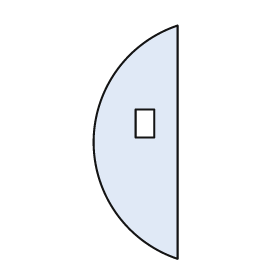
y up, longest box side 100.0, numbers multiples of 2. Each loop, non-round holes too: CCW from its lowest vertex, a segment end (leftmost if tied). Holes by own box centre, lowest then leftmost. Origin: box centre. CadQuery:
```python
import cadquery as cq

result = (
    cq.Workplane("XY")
    .moveTo(18.0, -50.0)
    .lineTo(18.0, 50.0)
    .threePointArc((-18.0, 0.0), (18.0, -50.0))
    .close()
    .moveTo(0.0, 2.0)
    .lineTo(8.0, 2.0)
    .lineTo(8.0, 14.0)
    .lineTo(0.0, 14.0)
    .close()
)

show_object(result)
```